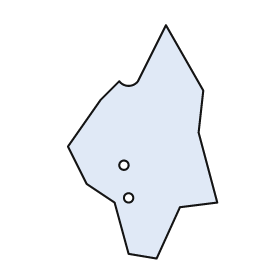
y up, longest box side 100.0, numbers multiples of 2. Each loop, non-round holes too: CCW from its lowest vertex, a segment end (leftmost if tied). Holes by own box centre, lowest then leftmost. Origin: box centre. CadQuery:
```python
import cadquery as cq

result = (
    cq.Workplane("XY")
    .moveTo(6.0, -50.0)
    .lineTo(16.0, -28.0)
    .lineTo(32.0, -26.0)
    .lineTo(24.0, 4.0)
    .lineTo(26.0, 22.0)
    .lineTo(10.0, 50.0)
    .lineTo(-2.0, 26.0)
    .threePointArc((-6.0, 24.0), (-10.0, 26.0))
    .lineTo(-18.0, 18.0)
    .lineTo(-32.0, -2.0)
    .lineTo(-24.0, -18.0)
    .lineTo(-12.0, -26.0)
    .lineTo(-6.0, -48.0)
    .close()
    .moveTo(-6.0, -24.0)
    .circle(2.0)
    .moveTo(-8.0, -10.0)
    .circle(2.0)
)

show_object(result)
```